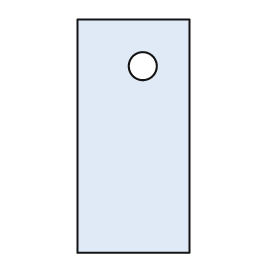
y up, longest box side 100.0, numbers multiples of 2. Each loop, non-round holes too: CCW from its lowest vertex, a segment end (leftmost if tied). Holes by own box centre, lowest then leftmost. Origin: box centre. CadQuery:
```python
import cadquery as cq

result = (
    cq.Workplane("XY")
    .moveTo(-24.0, -50.0)
    .lineTo(24.0, -50.0)
    .lineTo(24.0, 50.0)
    .lineTo(-24.0, 50.0)
    .close()
    .moveTo(4.0, 30.0)
    .circle(6.0)
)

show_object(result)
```